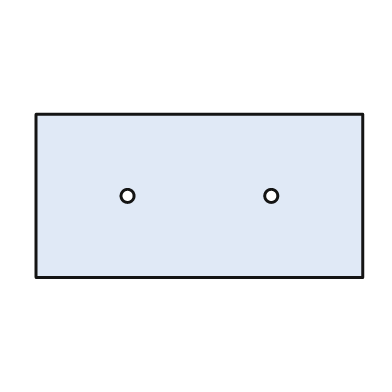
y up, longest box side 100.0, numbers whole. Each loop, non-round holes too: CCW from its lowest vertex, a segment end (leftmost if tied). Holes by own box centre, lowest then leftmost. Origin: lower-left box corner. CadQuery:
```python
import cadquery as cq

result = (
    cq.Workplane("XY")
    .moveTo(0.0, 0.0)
    .lineTo(100.0, 0.0)
    .lineTo(100.0, 50.0)
    .lineTo(0.0, 50.0)
    .close()
    .moveTo(28.0, 25.0)
    .circle(2.0)
    .moveTo(72.0, 25.0)
    .circle(2.0)
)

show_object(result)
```